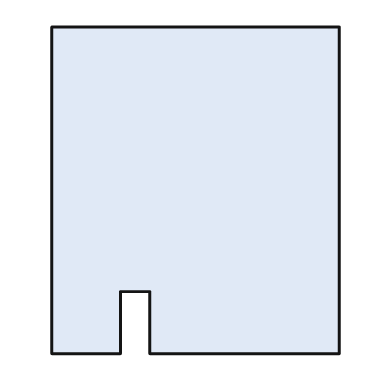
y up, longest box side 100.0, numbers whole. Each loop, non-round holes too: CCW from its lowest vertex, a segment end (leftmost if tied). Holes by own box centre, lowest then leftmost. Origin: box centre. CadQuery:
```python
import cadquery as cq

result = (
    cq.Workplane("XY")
    .moveTo(-44.0, -50.0)
    .lineTo(-23.0, -50.0)
    .lineTo(-23.0, -31.0)
    .lineTo(-14.0, -31.0)
    .lineTo(-14.0, -50.0)
    .lineTo(44.0, -50.0)
    .lineTo(44.0, 50.0)
    .lineTo(-44.0, 50.0)
    .close()
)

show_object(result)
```